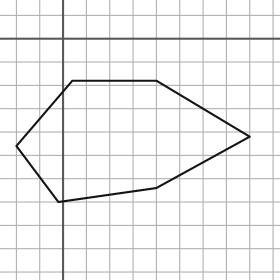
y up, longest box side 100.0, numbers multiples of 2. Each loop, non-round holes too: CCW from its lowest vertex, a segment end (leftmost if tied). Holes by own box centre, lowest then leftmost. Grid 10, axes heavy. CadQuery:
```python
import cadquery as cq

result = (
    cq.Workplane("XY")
    .moveTo(-2.0, -70.0)
    .lineTo(40.0, -64.0)
    .lineTo(80.0, -42.0)
    .lineTo(40.0, -18.0)
    .lineTo(4.0, -18.0)
    .lineTo(-20.0, -46.0)
    .close()
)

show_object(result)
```